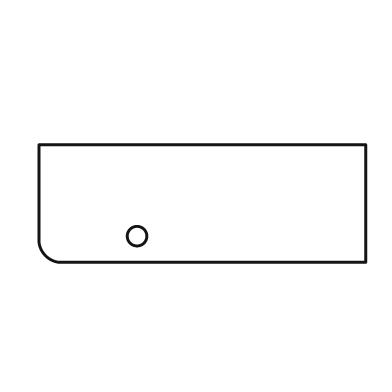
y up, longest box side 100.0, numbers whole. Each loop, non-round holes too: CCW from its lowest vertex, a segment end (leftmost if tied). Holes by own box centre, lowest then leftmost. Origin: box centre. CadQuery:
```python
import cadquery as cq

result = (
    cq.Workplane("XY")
    .moveTo(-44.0, -18.0)
    .lineTo(50.0, -18.0)
    .lineTo(50.0, 18.0)
    .lineTo(-50.0, 18.0)
    .lineTo(-50.0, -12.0)
    .threePointArc((-48.0, -16.0), (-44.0, -18.0))
    .close()
    .moveTo(-20.0, -10.0)
    .circle(3.0)
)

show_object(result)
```